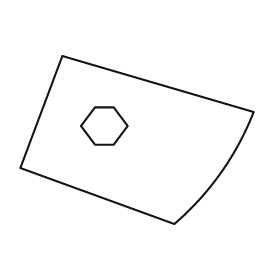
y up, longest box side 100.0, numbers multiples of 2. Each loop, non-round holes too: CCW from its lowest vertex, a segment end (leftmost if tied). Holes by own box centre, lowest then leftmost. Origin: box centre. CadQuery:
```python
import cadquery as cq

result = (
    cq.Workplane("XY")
    .moveTo(16.0, -36.0)
    .threePointArc((36.0, -14.0), (50.0, 12.0))
    .lineTo(-32.0, 36.0)
    .lineTo(-50.0, -12.0)
    .close()
    .moveTo(-18.0, -2.0)
    .lineTo(-10.0, -2.0)
    .lineTo(-4.0, 6.0)
    .lineTo(-10.0, 14.0)
    .lineTo(-18.0, 14.0)
    .lineTo(-24.0, 6.0)
    .close()
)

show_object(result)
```